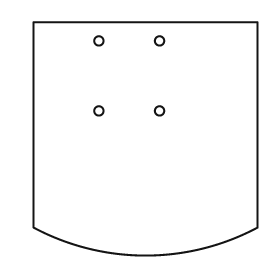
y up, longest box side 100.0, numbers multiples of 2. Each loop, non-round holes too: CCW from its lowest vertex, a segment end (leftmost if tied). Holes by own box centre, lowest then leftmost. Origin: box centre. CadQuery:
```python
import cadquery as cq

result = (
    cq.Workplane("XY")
    .moveTo(-48.0, -38.0)
    .threePointArc((0.0, -50.0), (48.0, -38.0))
    .lineTo(48.0, 50.0)
    .lineTo(-48.0, 50.0)
    .close()
    .moveTo(-20.0, 12.0)
    .circle(2.0)
    .moveTo(6.0, 12.0)
    .circle(2.0)
    .moveTo(-20.0, 42.0)
    .circle(2.0)
    .moveTo(6.0, 42.0)
    .circle(2.0)
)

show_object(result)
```